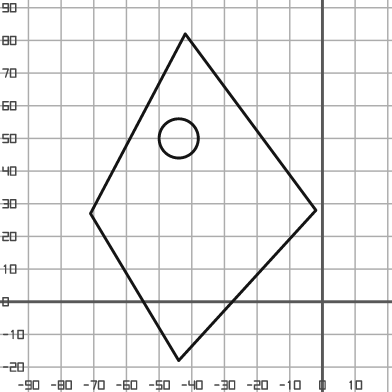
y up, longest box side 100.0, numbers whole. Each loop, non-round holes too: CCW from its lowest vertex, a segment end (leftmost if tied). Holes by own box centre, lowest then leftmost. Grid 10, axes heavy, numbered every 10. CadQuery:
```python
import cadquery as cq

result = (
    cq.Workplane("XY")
    .moveTo(-44.0, -18.0)
    .lineTo(-2.0, 28.0)
    .lineTo(-42.0, 82.0)
    .lineTo(-71.0, 27.0)
    .close()
    .moveTo(-44.0, 50.0)
    .circle(6.0)
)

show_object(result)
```